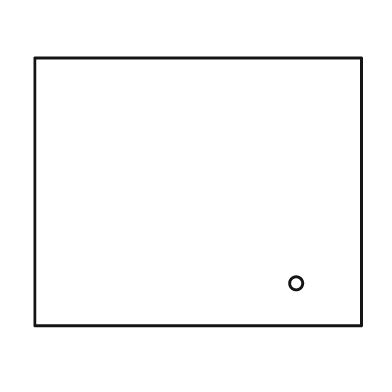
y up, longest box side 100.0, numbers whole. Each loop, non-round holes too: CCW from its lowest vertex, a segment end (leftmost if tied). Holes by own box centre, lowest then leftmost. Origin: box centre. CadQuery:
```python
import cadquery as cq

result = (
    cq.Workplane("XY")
    .moveTo(-50.0, -41.0)
    .lineTo(50.0, -41.0)
    .lineTo(50.0, 41.0)
    .lineTo(-50.0, 41.0)
    .close()
    .moveTo(30.0, -28.0)
    .circle(2.0)
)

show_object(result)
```